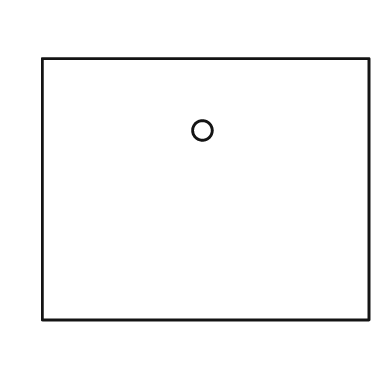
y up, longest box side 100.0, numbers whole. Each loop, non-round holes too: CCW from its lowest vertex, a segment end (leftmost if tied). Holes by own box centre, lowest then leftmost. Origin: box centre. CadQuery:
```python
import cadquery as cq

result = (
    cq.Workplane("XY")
    .moveTo(-50.0, -40.0)
    .lineTo(50.0, -40.0)
    .lineTo(50.0, 40.0)
    .lineTo(-50.0, 40.0)
    .close()
    .moveTo(-1.0, 18.0)
    .circle(3.0)
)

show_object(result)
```